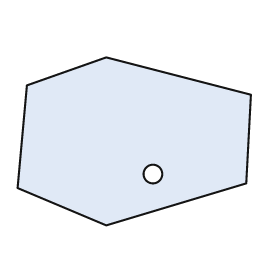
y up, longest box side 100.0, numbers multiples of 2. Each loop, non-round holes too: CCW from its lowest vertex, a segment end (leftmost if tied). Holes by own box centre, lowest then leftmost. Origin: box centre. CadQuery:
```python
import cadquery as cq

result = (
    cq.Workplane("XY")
    .moveTo(-12.0, -36.0)
    .lineTo(48.0, -18.0)
    .lineTo(50.0, 20.0)
    .lineTo(-12.0, 36.0)
    .lineTo(-46.0, 24.0)
    .lineTo(-50.0, -20.0)
    .close()
    .moveTo(8.0, -14.0)
    .circle(4.0)
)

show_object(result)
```